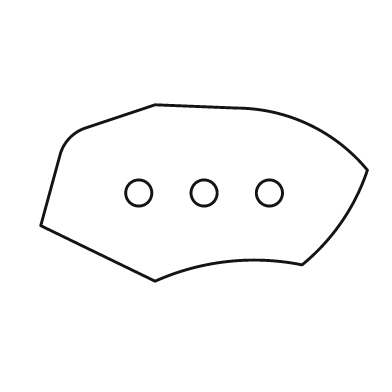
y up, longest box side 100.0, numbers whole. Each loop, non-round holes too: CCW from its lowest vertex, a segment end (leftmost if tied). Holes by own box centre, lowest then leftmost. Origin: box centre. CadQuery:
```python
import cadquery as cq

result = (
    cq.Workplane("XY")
    .moveTo(-15.0, -27.0)
    .threePointArc((7.0, -21.0), (30.0, -22.0))
    .threePointArc((42.0, -9.0), (50.0, 7.0))
    .threePointArc((32.0, 21.0), (10.0, 26.0))
    .lineTo(-15.0, 27.0)
    .lineTo(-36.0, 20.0)
    .threePointArc((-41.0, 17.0), (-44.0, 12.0))
    .lineTo(-50.0, -10.0)
    .close()
    .moveTo(-20.0, 0.0)
    .circle(4.0)
    .moveTo(0.0, 0.0)
    .circle(4.0)
    .moveTo(20.0, 0.0)
    .circle(4.0)
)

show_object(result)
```